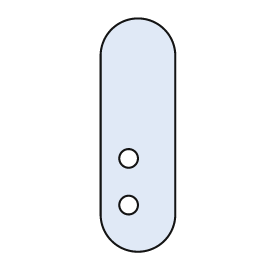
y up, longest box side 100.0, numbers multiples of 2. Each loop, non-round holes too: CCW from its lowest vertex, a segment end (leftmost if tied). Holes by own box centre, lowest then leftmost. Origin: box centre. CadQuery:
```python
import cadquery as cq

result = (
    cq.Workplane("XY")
    .moveTo(-16.0, -34.0)
    .threePointArc((0.0, -50.0), (16.0, -34.0))
    .lineTo(16.0, 34.0)
    .threePointArc((0.0, 50.0), (-16.0, 34.0))
    .close()
    .moveTo(-4.0, -30.0)
    .circle(4.0)
    .moveTo(-4.0, -10.0)
    .circle(4.0)
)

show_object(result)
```